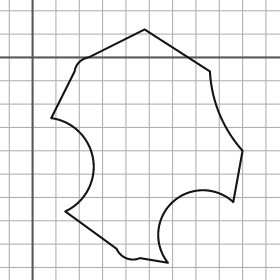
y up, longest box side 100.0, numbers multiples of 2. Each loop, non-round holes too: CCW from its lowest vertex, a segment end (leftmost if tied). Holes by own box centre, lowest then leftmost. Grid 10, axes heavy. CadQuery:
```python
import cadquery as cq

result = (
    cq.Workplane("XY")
    .moveTo(58.0, -88.0)
    .threePointArc((60.0, -62.0), (86.0, -62.0))
    .lineTo(90.0, -40.0)
    .threePointArc((80.0, -24.0), (76.0, -6.0))
    .lineTo(48.0, 12.0)
    .lineTo(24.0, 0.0)
    .threePointArc((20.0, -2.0), (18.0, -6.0))
    .lineTo(8.0, -26.0)
    .threePointArc((26.0, -44.0), (14.0, -66.0))
    .lineTo(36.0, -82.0)
    .threePointArc((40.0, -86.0), (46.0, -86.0))
    .close()
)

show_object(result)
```